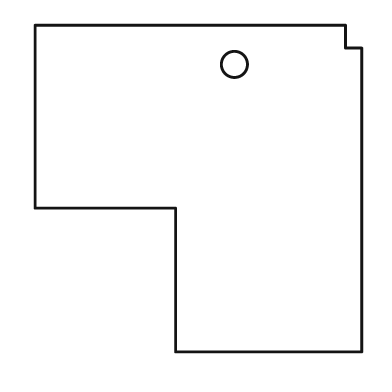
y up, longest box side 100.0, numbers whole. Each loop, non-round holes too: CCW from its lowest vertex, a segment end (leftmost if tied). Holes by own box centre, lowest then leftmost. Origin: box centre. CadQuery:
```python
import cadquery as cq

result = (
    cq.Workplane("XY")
    .moveTo(-7.0, -50.0)
    .lineTo(50.0, -50.0)
    .lineTo(50.0, 43.0)
    .lineTo(45.0, 43.0)
    .lineTo(45.0, 50.0)
    .lineTo(-50.0, 50.0)
    .lineTo(-50.0, -6.0)
    .lineTo(-7.0, -6.0)
    .close()
    .moveTo(11.0, 38.0)
    .circle(4.0)
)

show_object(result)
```